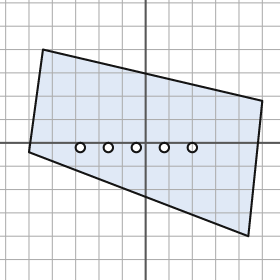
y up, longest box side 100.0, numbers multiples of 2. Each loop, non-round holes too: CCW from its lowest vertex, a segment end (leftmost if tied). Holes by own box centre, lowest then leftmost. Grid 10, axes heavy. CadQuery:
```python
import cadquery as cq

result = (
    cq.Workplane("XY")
    .moveTo(44.0, -40.0)
    .lineTo(50.0, 18.0)
    .lineTo(-44.0, 40.0)
    .lineTo(-50.0, -4.0)
    .close()
    .moveTo(-28.0, -2.0)
    .circle(2.0)
    .moveTo(-16.0, -2.0)
    .circle(2.0)
    .moveTo(-4.0, -2.0)
    .circle(2.0)
    .moveTo(8.0, -2.0)
    .circle(2.0)
    .moveTo(20.0, -2.0)
    .circle(2.0)
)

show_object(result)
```